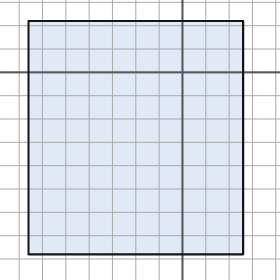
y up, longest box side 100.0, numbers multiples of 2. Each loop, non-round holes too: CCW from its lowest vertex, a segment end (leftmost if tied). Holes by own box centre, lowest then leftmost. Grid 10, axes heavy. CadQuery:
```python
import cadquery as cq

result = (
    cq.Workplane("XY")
    .moveTo(-66.0, -78.0)
    .lineTo(26.0, -78.0)
    .lineTo(26.0, 22.0)
    .lineTo(-66.0, 22.0)
    .close()
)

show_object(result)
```